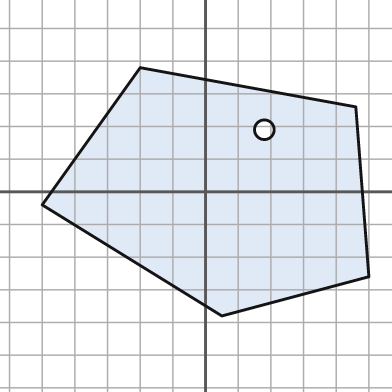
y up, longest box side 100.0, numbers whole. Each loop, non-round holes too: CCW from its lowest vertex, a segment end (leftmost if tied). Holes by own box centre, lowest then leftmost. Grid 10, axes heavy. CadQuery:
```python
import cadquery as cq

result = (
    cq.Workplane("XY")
    .moveTo(5.0, -38.0)
    .lineTo(50.0, -26.0)
    .lineTo(46.0, 26.0)
    .lineTo(-20.0, 38.0)
    .lineTo(-50.0, -4.0)
    .close()
    .moveTo(18.0, 19.0)
    .circle(3.0)
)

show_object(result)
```